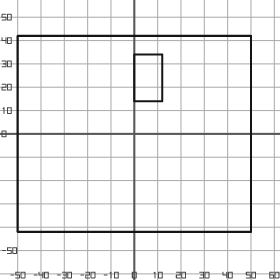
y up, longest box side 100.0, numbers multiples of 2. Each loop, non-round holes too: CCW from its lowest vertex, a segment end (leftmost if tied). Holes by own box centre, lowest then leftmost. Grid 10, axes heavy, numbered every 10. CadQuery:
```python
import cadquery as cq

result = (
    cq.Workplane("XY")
    .moveTo(-50.0, -42.0)
    .lineTo(50.0, -42.0)
    .lineTo(50.0, 42.0)
    .lineTo(-50.0, 42.0)
    .close()
    .moveTo(0.0, 14.0)
    .lineTo(12.0, 14.0)
    .lineTo(12.0, 34.0)
    .lineTo(0.0, 34.0)
    .close()
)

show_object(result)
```